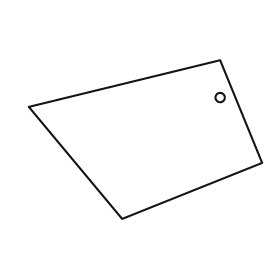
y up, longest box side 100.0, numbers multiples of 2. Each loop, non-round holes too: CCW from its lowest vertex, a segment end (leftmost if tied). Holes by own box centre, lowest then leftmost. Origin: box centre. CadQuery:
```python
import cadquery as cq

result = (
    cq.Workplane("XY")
    .moveTo(-10.0, -34.0)
    .lineTo(50.0, -10.0)
    .lineTo(32.0, 34.0)
    .lineTo(-50.0, 14.0)
    .close()
    .moveTo(32.0, 18.0)
    .circle(2.0)
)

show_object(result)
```